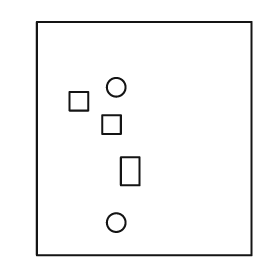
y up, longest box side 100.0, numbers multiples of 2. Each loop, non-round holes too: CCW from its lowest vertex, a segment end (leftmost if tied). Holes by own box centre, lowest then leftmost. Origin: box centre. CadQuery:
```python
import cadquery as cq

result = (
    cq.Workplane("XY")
    .moveTo(-46.0, -50.0)
    .lineTo(46.0, -50.0)
    .lineTo(46.0, 50.0)
    .lineTo(-46.0, 50.0)
    .close()
    .moveTo(-12.0, -36.0)
    .circle(4.0)
    .moveTo(-10.0, -20.0)
    .lineTo(-2.0, -20.0)
    .lineTo(-2.0, -8.0)
    .lineTo(-10.0, -8.0)
    .close()
    .moveTo(-18.0, 2.0)
    .lineTo(-10.0, 2.0)
    .lineTo(-10.0, 10.0)
    .lineTo(-18.0, 10.0)
    .close()
    .moveTo(-32.0, 12.0)
    .lineTo(-24.0, 12.0)
    .lineTo(-24.0, 20.0)
    .lineTo(-32.0, 20.0)
    .close()
    .moveTo(-12.0, 22.0)
    .circle(4.0)
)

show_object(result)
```